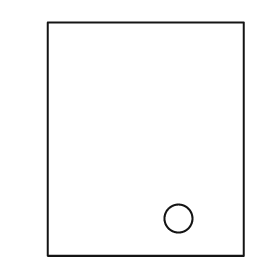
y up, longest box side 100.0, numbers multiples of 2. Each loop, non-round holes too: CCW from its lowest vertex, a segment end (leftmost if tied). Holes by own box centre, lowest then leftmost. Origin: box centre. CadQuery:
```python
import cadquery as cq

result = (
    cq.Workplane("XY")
    .moveTo(-42.0, -50.0)
    .lineTo(42.0, -50.0)
    .lineTo(42.0, 50.0)
    .lineTo(-42.0, 50.0)
    .close()
    .moveTo(14.0, -34.0)
    .circle(6.0)
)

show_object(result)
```